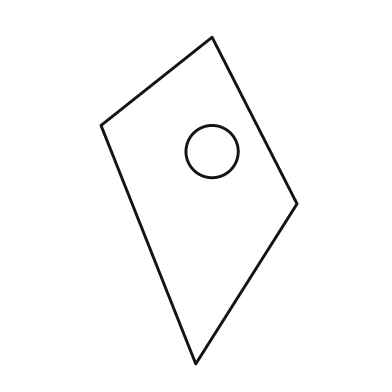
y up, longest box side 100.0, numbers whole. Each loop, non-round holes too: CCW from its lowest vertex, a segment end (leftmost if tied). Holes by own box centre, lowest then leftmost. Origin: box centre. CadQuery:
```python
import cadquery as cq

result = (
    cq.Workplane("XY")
    .moveTo(-1.0, -50.0)
    .lineTo(30.0, -1.0)
    .lineTo(4.0, 50.0)
    .lineTo(-30.0, 23.0)
    .close()
    .moveTo(4.0, 15.0)
    .circle(8.0)
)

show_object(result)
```